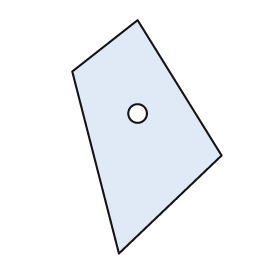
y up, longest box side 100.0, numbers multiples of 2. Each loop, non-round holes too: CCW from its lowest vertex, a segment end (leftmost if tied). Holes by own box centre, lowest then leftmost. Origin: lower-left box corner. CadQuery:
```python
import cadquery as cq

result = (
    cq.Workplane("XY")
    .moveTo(20.0, 0.0)
    .lineTo(64.0, 42.0)
    .lineTo(28.0, 100.0)
    .lineTo(0.0, 78.0)
    .close()
    .moveTo(28.0, 60.0)
    .circle(4.0)
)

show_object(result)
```